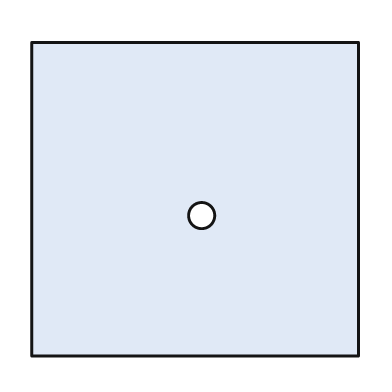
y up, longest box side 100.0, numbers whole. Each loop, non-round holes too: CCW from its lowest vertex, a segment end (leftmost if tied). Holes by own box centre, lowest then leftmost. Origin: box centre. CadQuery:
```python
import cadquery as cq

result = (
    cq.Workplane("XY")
    .moveTo(-50.0, -48.0)
    .lineTo(50.0, -48.0)
    .lineTo(50.0, 48.0)
    .lineTo(-50.0, 48.0)
    .close()
    .moveTo(2.0, -5.0)
    .circle(4.0)
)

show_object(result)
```